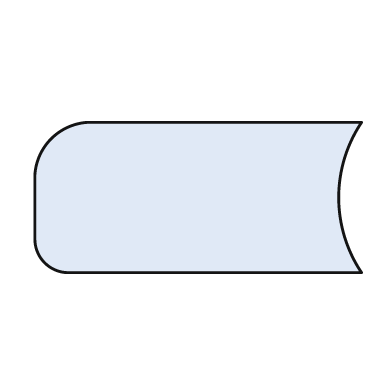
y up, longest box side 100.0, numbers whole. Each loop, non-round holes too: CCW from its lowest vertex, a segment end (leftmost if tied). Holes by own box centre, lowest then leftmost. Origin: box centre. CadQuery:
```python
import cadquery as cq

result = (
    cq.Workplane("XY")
    .moveTo(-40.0, -23.0)
    .lineTo(50.0, -23.0)
    .threePointArc((43.0, 0.0), (50.0, 23.0))
    .lineTo(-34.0, 23.0)
    .threePointArc((-45.0, 18.0), (-50.0, 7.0))
    .lineTo(-50.0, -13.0)
    .threePointArc((-47.0, -20.0), (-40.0, -23.0))
    .close()
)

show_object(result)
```